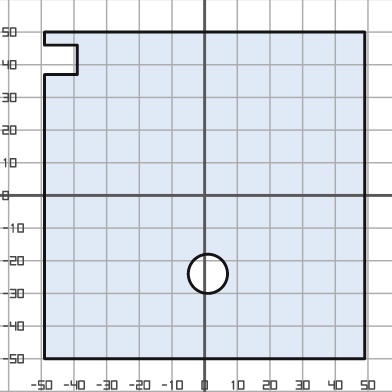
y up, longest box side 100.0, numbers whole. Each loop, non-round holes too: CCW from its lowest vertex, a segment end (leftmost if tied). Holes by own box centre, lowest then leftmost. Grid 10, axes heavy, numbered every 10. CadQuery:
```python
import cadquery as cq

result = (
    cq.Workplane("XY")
    .moveTo(-49.0, -50.0)
    .lineTo(49.0, -50.0)
    .lineTo(49.0, 50.0)
    .lineTo(-49.0, 50.0)
    .lineTo(-49.0, 46.0)
    .lineTo(-39.0, 46.0)
    .lineTo(-39.0, 37.0)
    .lineTo(-49.0, 37.0)
    .close()
    .moveTo(1.0, -24.0)
    .circle(6.0)
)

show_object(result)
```